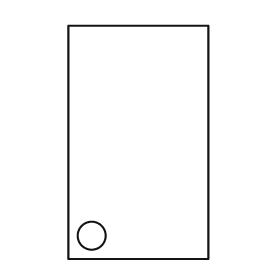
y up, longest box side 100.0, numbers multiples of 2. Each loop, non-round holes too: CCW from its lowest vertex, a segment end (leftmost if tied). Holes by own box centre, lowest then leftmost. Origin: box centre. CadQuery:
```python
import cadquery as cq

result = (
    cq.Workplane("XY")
    .moveTo(-30.0, -50.0)
    .lineTo(30.0, -50.0)
    .lineTo(30.0, 50.0)
    .lineTo(-30.0, 50.0)
    .close()
    .moveTo(-20.0, -40.0)
    .circle(6.0)
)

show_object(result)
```